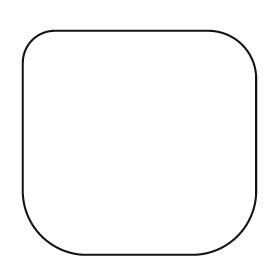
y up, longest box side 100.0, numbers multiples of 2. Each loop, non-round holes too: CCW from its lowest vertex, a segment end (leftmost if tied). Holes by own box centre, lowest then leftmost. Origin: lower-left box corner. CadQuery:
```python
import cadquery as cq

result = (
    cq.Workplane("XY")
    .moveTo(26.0, 0.0)
    .lineTo(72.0, 0.0)
    .threePointArc((92.0, 8.0), (100.0, 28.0))
    .lineTo(100.0, 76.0)
    .threePointArc((94.0, 90.0), (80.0, 96.0))
    .lineTo(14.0, 96.0)
    .threePointArc((4.0, 92.0), (0.0, 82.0))
    .lineTo(0.0, 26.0)
    .threePointArc((8.0, 8.0), (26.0, 0.0))
    .close()
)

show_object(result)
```